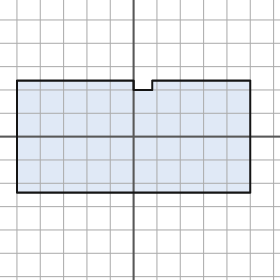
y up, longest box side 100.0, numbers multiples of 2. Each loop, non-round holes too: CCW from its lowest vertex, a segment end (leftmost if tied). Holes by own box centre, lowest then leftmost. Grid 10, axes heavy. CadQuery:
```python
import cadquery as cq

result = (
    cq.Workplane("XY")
    .moveTo(-50.0, -24.0)
    .lineTo(50.0, -24.0)
    .lineTo(50.0, 24.0)
    .lineTo(8.0, 24.0)
    .lineTo(8.0, 20.0)
    .lineTo(0.0, 20.0)
    .lineTo(0.0, 24.0)
    .lineTo(-50.0, 24.0)
    .close()
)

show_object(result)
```